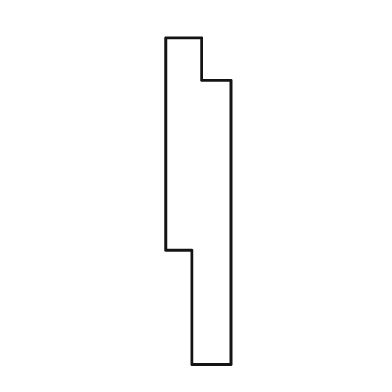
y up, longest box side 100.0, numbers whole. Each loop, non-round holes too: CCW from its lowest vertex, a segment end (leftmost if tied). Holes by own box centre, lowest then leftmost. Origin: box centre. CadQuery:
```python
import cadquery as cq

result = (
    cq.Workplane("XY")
    .moveTo(-2.0, -50.0)
    .lineTo(10.0, -50.0)
    .lineTo(10.0, 37.0)
    .lineTo(1.0, 37.0)
    .lineTo(1.0, 50.0)
    .lineTo(-10.0, 50.0)
    .lineTo(-10.0, -15.0)
    .lineTo(-2.0, -15.0)
    .close()
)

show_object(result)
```